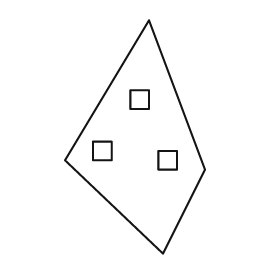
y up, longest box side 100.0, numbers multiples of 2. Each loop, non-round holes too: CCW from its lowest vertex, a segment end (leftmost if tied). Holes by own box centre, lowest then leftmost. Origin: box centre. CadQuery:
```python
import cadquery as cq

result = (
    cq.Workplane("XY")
    .moveTo(12.0, -50.0)
    .lineTo(30.0, -14.0)
    .lineTo(6.0, 50.0)
    .lineTo(-30.0, -10.0)
    .close()
    .moveTo(10.0, -14.0)
    .lineTo(18.0, -14.0)
    .lineTo(18.0, -6.0)
    .lineTo(10.0, -6.0)
    .close()
    .moveTo(-18.0, -10.0)
    .lineTo(-10.0, -10.0)
    .lineTo(-10.0, -2.0)
    .lineTo(-18.0, -2.0)
    .close()
    .moveTo(-2.0, 12.0)
    .lineTo(6.0, 12.0)
    .lineTo(6.0, 20.0)
    .lineTo(-2.0, 20.0)
    .close()
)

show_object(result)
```